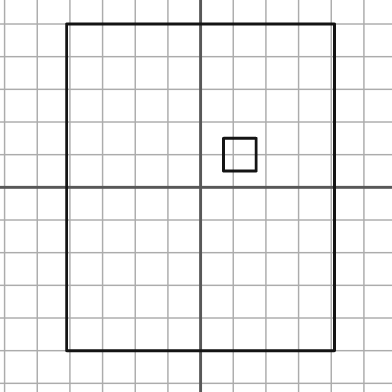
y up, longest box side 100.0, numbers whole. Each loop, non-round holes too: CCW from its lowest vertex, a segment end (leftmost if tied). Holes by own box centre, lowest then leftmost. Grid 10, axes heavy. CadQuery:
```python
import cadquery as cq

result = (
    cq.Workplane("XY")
    .moveTo(-41.0, -50.0)
    .lineTo(41.0, -50.0)
    .lineTo(41.0, 50.0)
    .lineTo(-41.0, 50.0)
    .close()
    .moveTo(7.0, 5.0)
    .lineTo(17.0, 5.0)
    .lineTo(17.0, 15.0)
    .lineTo(7.0, 15.0)
    .close()
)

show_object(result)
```